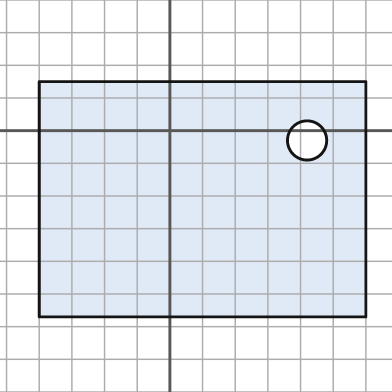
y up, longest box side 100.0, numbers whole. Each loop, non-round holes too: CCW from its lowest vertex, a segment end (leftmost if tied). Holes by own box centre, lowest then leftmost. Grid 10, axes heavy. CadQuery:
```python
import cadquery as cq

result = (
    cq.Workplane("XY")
    .moveTo(-40.0, -57.0)
    .lineTo(60.0, -57.0)
    .lineTo(60.0, 15.0)
    .lineTo(-40.0, 15.0)
    .close()
    .moveTo(42.0, -3.0)
    .circle(6.0)
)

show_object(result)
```